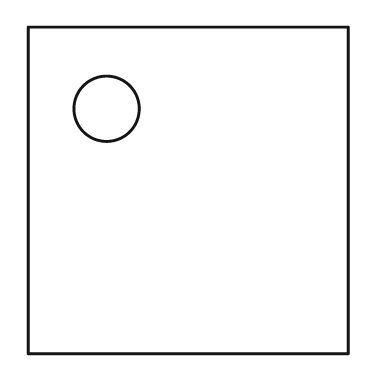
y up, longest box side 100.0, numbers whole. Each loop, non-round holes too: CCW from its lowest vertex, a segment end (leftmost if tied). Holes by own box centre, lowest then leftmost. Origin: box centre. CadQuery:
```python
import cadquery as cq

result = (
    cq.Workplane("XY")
    .moveTo(-49.0, -50.0)
    .lineTo(49.0, -50.0)
    .lineTo(49.0, 50.0)
    .lineTo(-49.0, 50.0)
    .close()
    .moveTo(-25.0, 25.0)
    .circle(10.0)
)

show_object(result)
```